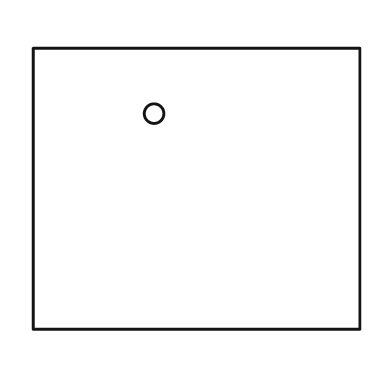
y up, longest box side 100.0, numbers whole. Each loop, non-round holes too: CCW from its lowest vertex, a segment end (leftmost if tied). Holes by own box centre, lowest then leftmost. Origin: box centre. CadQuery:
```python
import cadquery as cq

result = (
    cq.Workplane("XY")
    .moveTo(-50.0, -43.0)
    .lineTo(50.0, -43.0)
    .lineTo(50.0, 43.0)
    .lineTo(-50.0, 43.0)
    .close()
    .moveTo(-13.0, 23.0)
    .circle(3.0)
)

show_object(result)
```